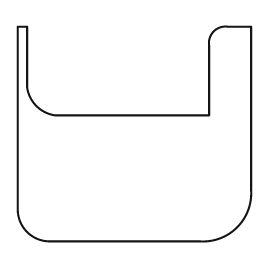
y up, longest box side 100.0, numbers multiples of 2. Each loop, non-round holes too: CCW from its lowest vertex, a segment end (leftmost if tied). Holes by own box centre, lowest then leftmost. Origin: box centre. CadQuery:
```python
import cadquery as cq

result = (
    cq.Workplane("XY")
    .moveTo(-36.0, -46.0)
    .lineTo(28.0, -46.0)
    .threePointArc((44.0, -40.0), (50.0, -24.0))
    .lineTo(50.0, 46.0)
    .lineTo(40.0, 46.0)
    .threePointArc((34.0, 44.0), (32.0, 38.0))
    .lineTo(32.0, 8.0)
    .lineTo(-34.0, 8.0)
    .threePointArc((-42.0, 12.0), (-46.0, 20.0))
    .lineTo(-46.0, 46.0)
    .lineTo(-50.0, 46.0)
    .lineTo(-50.0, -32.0)
    .threePointArc((-46.0, -42.0), (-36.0, -46.0))
    .close()
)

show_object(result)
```